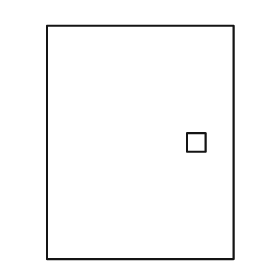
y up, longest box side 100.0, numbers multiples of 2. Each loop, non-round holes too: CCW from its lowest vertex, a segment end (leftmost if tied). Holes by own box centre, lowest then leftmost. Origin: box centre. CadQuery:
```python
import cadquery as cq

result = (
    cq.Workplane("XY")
    .moveTo(-40.0, -50.0)
    .lineTo(40.0, -50.0)
    .lineTo(40.0, 50.0)
    .lineTo(-40.0, 50.0)
    .close()
    .moveTo(20.0, -4.0)
    .lineTo(28.0, -4.0)
    .lineTo(28.0, 4.0)
    .lineTo(20.0, 4.0)
    .close()
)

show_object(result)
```